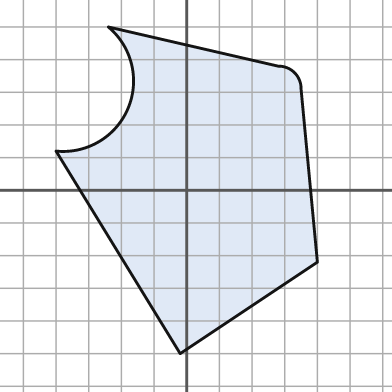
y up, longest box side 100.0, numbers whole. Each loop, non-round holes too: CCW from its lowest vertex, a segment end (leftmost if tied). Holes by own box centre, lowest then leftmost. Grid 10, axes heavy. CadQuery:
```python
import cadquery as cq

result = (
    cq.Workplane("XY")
    .moveTo(-2.0, -50.0)
    .lineTo(40.0, -22.0)
    .lineTo(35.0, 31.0)
    .threePointArc((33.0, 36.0), (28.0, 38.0))
    .lineTo(-24.0, 50.0)
    .threePointArc((-18.0, 25.0), (-40.0, 12.0))
    .close()
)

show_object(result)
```